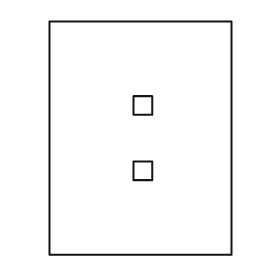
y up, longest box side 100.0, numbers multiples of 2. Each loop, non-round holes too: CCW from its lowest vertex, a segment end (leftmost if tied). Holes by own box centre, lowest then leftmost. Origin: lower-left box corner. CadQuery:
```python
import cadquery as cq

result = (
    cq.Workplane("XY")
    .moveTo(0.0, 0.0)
    .lineTo(78.0, 0.0)
    .lineTo(78.0, 100.0)
    .lineTo(0.0, 100.0)
    .close()
    .moveTo(36.0, 32.0)
    .lineTo(44.0, 32.0)
    .lineTo(44.0, 40.0)
    .lineTo(36.0, 40.0)
    .close()
    .moveTo(36.0, 60.0)
    .lineTo(44.0, 60.0)
    .lineTo(44.0, 68.0)
    .lineTo(36.0, 68.0)
    .close()
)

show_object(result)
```